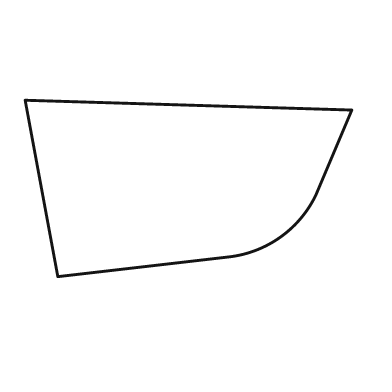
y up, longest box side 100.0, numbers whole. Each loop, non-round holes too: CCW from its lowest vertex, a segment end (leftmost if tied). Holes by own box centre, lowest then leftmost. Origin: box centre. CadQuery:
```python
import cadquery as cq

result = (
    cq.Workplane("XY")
    .moveTo(-40.0, -27.0)
    .lineTo(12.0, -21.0)
    .threePointArc((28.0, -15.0), (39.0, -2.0))
    .lineTo(50.0, 24.0)
    .lineTo(-50.0, 27.0)
    .close()
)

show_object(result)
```